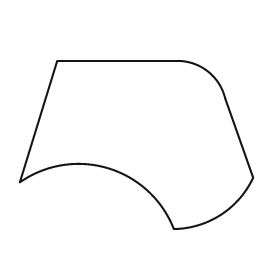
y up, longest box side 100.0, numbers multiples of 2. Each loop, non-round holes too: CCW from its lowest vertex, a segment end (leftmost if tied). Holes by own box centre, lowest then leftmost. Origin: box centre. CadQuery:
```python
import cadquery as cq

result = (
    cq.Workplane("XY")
    .moveTo(16.0, -36.0)
    .threePointArc((36.0, -30.0), (50.0, -14.0))
    .lineTo(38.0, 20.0)
    .threePointArc((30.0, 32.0), (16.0, 36.0))
    .lineTo(-34.0, 36.0)
    .lineTo(-50.0, -16.0)
    .threePointArc((-12.0, -10.0), (16.0, -36.0))
    .close()
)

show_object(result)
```